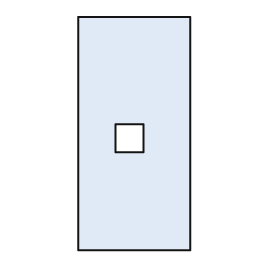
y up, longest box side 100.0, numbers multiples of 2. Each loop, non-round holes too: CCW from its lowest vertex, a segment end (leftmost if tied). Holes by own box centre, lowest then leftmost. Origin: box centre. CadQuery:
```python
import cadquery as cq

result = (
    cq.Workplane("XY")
    .moveTo(-24.0, -50.0)
    .lineTo(24.0, -50.0)
    .lineTo(24.0, 50.0)
    .lineTo(-24.0, 50.0)
    .close()
    .moveTo(-8.0, -8.0)
    .lineTo(4.0, -8.0)
    .lineTo(4.0, 4.0)
    .lineTo(-8.0, 4.0)
    .close()
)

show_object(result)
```